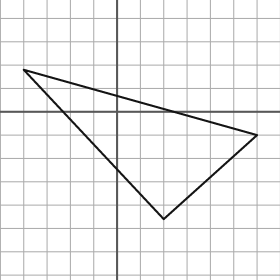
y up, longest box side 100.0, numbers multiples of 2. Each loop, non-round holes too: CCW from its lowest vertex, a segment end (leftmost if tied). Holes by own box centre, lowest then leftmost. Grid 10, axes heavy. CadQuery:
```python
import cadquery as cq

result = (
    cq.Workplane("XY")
    .moveTo(20.0, -46.0)
    .lineTo(60.0, -10.0)
    .lineTo(-40.0, 18.0)
    .close()
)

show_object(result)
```